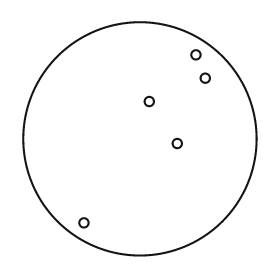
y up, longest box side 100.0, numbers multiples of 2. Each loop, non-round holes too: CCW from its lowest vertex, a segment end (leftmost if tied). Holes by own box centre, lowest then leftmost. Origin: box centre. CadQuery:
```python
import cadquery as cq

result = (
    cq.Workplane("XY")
    .moveTo(0.0, 0.0)
    .circle(50.0)
    .moveTo(-24.0, -36.0)
    .circle(2.0)
    .moveTo(16.0, -2.0)
    .circle(2.0)
    .moveTo(4.0, 16.0)
    .circle(2.0)
    .moveTo(28.0, 26.0)
    .circle(2.0)
    .moveTo(24.0, 36.0)
    .circle(2.0)
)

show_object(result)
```